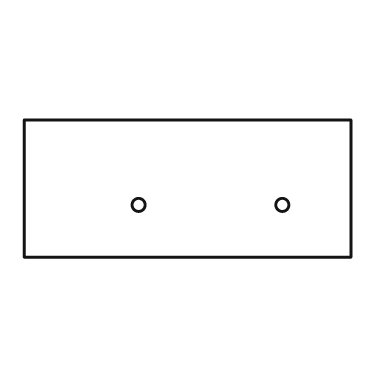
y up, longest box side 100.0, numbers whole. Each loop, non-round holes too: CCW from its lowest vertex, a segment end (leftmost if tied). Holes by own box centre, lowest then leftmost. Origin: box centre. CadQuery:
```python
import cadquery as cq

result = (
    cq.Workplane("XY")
    .moveTo(-50.0, -21.0)
    .lineTo(50.0, -21.0)
    .lineTo(50.0, 21.0)
    .lineTo(-50.0, 21.0)
    .close()
    .moveTo(-15.0, -5.0)
    .circle(2.0)
    .moveTo(29.0, -5.0)
    .circle(2.0)
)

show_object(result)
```